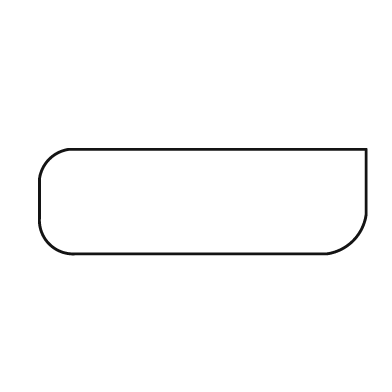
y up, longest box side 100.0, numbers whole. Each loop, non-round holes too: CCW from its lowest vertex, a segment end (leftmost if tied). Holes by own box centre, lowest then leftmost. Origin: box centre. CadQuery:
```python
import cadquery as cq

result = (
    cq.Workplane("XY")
    .moveTo(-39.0, -16.0)
    .lineTo(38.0, -16.0)
    .threePointArc((46.0, -12.0), (50.0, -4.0))
    .lineTo(50.0, 16.0)
    .lineTo(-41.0, 16.0)
    .threePointArc((-47.0, 13.0), (-50.0, 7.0))
    .lineTo(-50.0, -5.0)
    .threePointArc((-47.0, -13.0), (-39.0, -16.0))
    .close()
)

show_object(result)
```